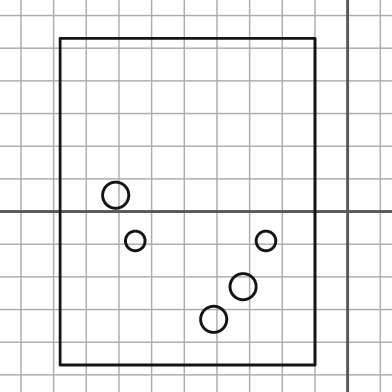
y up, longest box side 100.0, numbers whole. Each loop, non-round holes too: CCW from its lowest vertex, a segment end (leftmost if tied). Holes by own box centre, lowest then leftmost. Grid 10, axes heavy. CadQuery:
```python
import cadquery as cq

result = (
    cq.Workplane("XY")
    .moveTo(-88.0, -47.0)
    .lineTo(-10.0, -47.0)
    .lineTo(-10.0, 53.0)
    .lineTo(-88.0, 53.0)
    .close()
    .moveTo(-41.0, -33.0)
    .circle(4.0)
    .moveTo(-32.0, -23.0)
    .circle(4.0)
    .moveTo(-65.0, -9.0)
    .circle(3.0)
    .moveTo(-25.0, -9.0)
    .circle(3.0)
    .moveTo(-71.0, 5.0)
    .circle(4.0)
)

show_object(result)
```